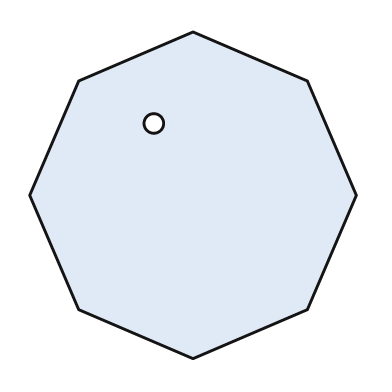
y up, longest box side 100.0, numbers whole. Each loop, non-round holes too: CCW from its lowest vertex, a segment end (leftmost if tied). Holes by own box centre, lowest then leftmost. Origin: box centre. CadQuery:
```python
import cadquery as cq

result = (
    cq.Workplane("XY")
    .moveTo(0.0, -50.0)
    .lineTo(35.0, -35.0)
    .lineTo(50.0, 0.0)
    .lineTo(35.0, 35.0)
    .lineTo(0.0, 50.0)
    .lineTo(-35.0, 35.0)
    .lineTo(-50.0, 0.0)
    .lineTo(-35.0, -35.0)
    .close()
    .moveTo(-12.0, 22.0)
    .circle(3.0)
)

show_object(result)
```